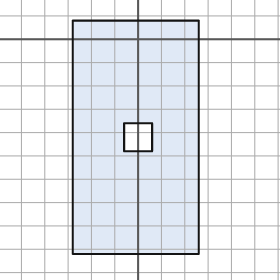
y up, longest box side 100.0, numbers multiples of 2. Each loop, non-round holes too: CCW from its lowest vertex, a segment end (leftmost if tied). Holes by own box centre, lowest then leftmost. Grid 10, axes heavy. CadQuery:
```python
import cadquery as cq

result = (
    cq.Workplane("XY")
    .moveTo(-28.0, -92.0)
    .lineTo(26.0, -92.0)
    .lineTo(26.0, 8.0)
    .lineTo(-28.0, 8.0)
    .close()
    .moveTo(-6.0, -48.0)
    .lineTo(6.0, -48.0)
    .lineTo(6.0, -36.0)
    .lineTo(-6.0, -36.0)
    .close()
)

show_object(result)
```